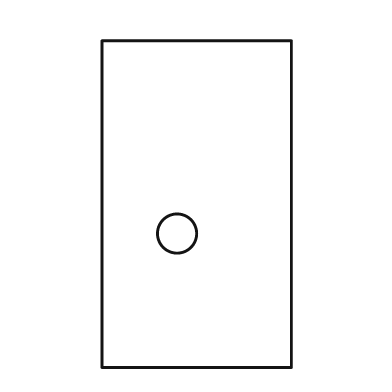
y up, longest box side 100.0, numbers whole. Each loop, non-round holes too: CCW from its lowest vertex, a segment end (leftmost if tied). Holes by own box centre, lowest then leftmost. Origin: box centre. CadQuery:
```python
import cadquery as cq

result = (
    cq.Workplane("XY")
    .moveTo(-29.0, -50.0)
    .lineTo(29.0, -50.0)
    .lineTo(29.0, 50.0)
    .lineTo(-29.0, 50.0)
    .close()
    .moveTo(-6.0, -9.0)
    .circle(6.0)
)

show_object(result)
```